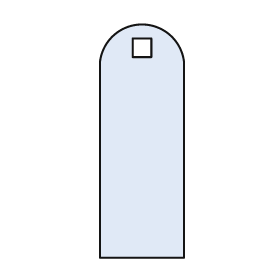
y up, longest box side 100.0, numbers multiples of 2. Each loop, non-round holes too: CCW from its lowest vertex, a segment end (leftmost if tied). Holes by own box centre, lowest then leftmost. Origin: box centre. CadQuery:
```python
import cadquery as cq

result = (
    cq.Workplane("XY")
    .moveTo(-18.0, -50.0)
    .lineTo(18.0, -50.0)
    .lineTo(18.0, 34.0)
    .threePointArc((0.0, 50.0), (-18.0, 34.0))
    .close()
    .moveTo(-4.0, 36.0)
    .lineTo(4.0, 36.0)
    .lineTo(4.0, 44.0)
    .lineTo(-4.0, 44.0)
    .close()
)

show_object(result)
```